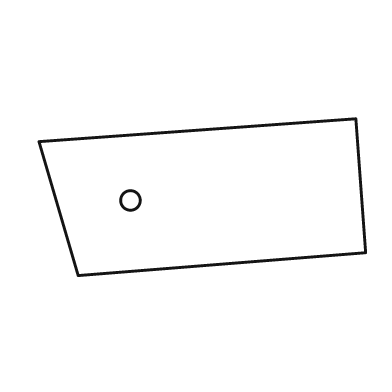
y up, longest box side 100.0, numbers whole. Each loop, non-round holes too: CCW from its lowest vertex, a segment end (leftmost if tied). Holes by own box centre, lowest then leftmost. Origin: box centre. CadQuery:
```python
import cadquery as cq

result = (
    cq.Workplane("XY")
    .moveTo(-38.0, -24.0)
    .lineTo(50.0, -17.0)
    .lineTo(47.0, 24.0)
    .lineTo(-50.0, 17.0)
    .close()
    .moveTo(-22.0, -1.0)
    .circle(3.0)
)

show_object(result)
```